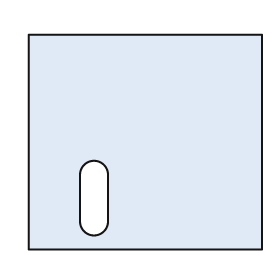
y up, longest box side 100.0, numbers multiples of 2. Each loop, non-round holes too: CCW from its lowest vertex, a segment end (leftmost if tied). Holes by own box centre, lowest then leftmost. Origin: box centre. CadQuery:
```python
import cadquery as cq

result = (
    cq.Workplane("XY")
    .moveTo(-50.0, -46.0)
    .lineTo(50.0, -46.0)
    .lineTo(50.0, 46.0)
    .lineTo(-50.0, 46.0)
    .close()
    .moveTo(-28.0, -34.0)
    .threePointArc((-22.0, -40.0), (-16.0, -34.0))
    .lineTo(-16.0, -14.0)
    .threePointArc((-22.0, -8.0), (-28.0, -14.0))
    .close()
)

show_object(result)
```